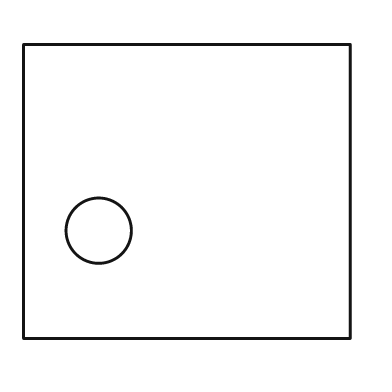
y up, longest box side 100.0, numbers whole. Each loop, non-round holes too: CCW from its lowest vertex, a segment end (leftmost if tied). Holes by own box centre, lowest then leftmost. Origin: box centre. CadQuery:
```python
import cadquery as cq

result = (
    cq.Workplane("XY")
    .moveTo(-50.0, -45.0)
    .lineTo(50.0, -45.0)
    .lineTo(50.0, 45.0)
    .lineTo(-50.0, 45.0)
    .close()
    .moveTo(-27.0, -12.0)
    .circle(10.0)
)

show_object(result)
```